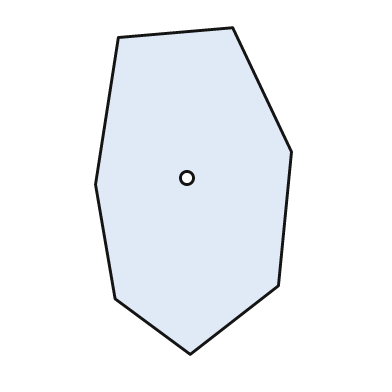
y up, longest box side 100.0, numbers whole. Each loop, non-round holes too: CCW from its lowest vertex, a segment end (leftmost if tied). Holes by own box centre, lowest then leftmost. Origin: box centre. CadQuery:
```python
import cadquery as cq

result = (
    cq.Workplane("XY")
    .moveTo(-1.0, -50.0)
    .lineTo(26.0, -29.0)
    .lineTo(30.0, 12.0)
    .lineTo(12.0, 50.0)
    .lineTo(-23.0, 47.0)
    .lineTo(-30.0, 2.0)
    .lineTo(-24.0, -33.0)
    .close()
    .moveTo(-2.0, 4.0)
    .circle(2.0)
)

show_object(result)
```